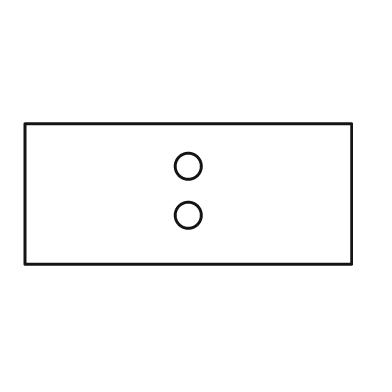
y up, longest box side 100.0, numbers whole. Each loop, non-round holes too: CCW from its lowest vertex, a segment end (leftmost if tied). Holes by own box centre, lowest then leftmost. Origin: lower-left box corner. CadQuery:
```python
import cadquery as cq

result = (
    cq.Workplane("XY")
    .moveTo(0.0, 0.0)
    .lineTo(100.0, 0.0)
    .lineTo(100.0, 43.0)
    .lineTo(0.0, 43.0)
    .close()
    .moveTo(50.0, 15.0)
    .circle(4.0)
    .moveTo(50.0, 30.0)
    .circle(4.0)
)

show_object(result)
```